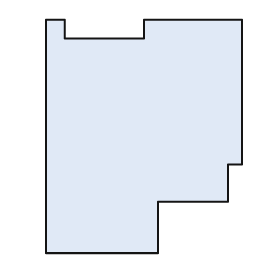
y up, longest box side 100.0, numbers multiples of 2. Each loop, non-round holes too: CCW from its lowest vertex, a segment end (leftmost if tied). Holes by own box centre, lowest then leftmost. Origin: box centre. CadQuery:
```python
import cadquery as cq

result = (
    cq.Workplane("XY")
    .moveTo(-42.0, -50.0)
    .lineTo(6.0, -50.0)
    .lineTo(6.0, -28.0)
    .lineTo(36.0, -28.0)
    .lineTo(36.0, -12.0)
    .lineTo(42.0, -12.0)
    .lineTo(42.0, 50.0)
    .lineTo(0.0, 50.0)
    .lineTo(0.0, 42.0)
    .lineTo(-34.0, 42.0)
    .lineTo(-34.0, 50.0)
    .lineTo(-42.0, 50.0)
    .close()
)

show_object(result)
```